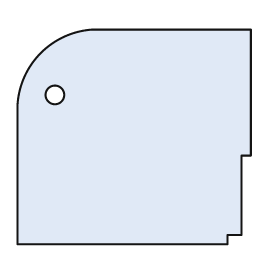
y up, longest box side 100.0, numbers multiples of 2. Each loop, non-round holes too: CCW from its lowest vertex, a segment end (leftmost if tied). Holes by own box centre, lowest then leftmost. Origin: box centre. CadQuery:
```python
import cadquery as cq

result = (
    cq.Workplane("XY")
    .moveTo(-50.0, -46.0)
    .lineTo(40.0, -46.0)
    .lineTo(40.0, -42.0)
    .lineTo(46.0, -42.0)
    .lineTo(46.0, -8.0)
    .lineTo(50.0, -8.0)
    .lineTo(50.0, 46.0)
    .lineTo(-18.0, 46.0)
    .threePointArc((-40.0, 36.0), (-50.0, 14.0))
    .close()
    .moveTo(-34.0, 18.0)
    .circle(4.0)
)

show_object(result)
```